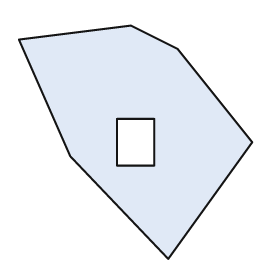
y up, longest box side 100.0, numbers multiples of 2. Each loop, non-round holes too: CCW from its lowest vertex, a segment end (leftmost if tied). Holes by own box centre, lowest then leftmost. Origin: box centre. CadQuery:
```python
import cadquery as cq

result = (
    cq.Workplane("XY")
    .moveTo(14.0, -50.0)
    .lineTo(50.0, 0.0)
    .lineTo(18.0, 40.0)
    .lineTo(-2.0, 50.0)
    .lineTo(-50.0, 44.0)
    .lineTo(-28.0, -6.0)
    .close()
    .moveTo(-8.0, -10.0)
    .lineTo(8.0, -10.0)
    .lineTo(8.0, 10.0)
    .lineTo(-8.0, 10.0)
    .close()
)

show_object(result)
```